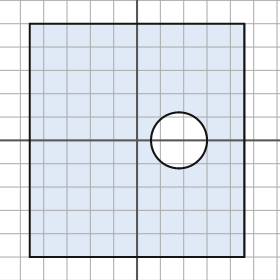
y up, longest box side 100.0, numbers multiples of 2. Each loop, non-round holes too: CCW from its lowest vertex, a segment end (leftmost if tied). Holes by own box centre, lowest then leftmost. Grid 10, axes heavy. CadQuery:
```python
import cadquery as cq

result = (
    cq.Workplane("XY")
    .moveTo(-46.0, -50.0)
    .lineTo(46.0, -50.0)
    .lineTo(46.0, 50.0)
    .lineTo(-46.0, 50.0)
    .close()
    .moveTo(18.0, 0.0)
    .circle(12.0)
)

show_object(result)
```